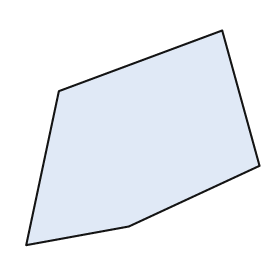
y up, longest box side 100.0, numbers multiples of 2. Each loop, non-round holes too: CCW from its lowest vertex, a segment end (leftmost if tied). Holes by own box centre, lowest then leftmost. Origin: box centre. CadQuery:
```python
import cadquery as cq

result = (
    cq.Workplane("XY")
    .moveTo(-50.0, -46.0)
    .lineTo(-6.0, -38.0)
    .lineTo(50.0, -12.0)
    .lineTo(34.0, 46.0)
    .lineTo(-36.0, 20.0)
    .close()
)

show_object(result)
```